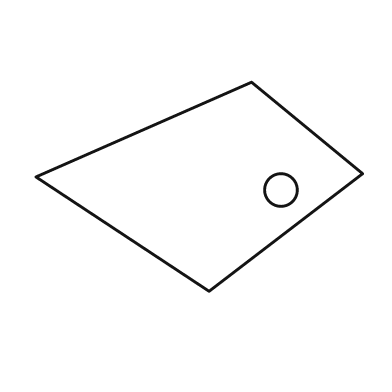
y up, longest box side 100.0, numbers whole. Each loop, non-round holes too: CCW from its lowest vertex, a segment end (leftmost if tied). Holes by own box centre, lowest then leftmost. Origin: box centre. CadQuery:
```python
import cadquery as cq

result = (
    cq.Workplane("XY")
    .moveTo(3.0, -32.0)
    .lineTo(50.0, 4.0)
    .lineTo(16.0, 32.0)
    .lineTo(-50.0, 3.0)
    .close()
    .moveTo(25.0, -1.0)
    .circle(5.0)
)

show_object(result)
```